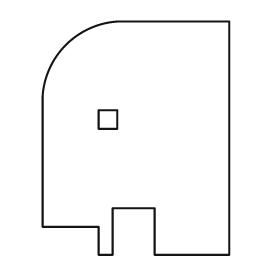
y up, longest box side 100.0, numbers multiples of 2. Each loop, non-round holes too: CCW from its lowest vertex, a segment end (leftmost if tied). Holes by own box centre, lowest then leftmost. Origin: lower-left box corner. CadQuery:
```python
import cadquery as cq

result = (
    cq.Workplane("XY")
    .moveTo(24.0, 0.0)
    .lineTo(30.0, 0.0)
    .lineTo(30.0, 20.0)
    .lineTo(48.0, 20.0)
    .lineTo(48.0, 0.0)
    .lineTo(80.0, 0.0)
    .lineTo(80.0, 100.0)
    .lineTo(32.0, 100.0)
    .threePointArc((10.0, 90.0), (0.0, 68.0))
    .lineTo(0.0, 12.0)
    .lineTo(24.0, 12.0)
    .close()
    .moveTo(24.0, 54.0)
    .lineTo(32.0, 54.0)
    .lineTo(32.0, 62.0)
    .lineTo(24.0, 62.0)
    .close()
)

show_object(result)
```